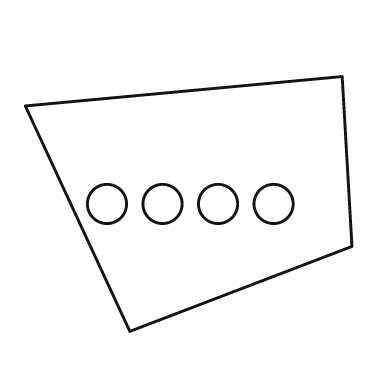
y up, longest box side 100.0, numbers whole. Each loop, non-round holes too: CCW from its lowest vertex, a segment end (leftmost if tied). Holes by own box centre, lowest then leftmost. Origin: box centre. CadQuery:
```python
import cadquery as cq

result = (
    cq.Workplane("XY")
    .moveTo(-18.0, -39.0)
    .lineTo(50.0, -13.0)
    .lineTo(47.0, 39.0)
    .lineTo(-50.0, 30.0)
    .close()
    .moveTo(-25.0, 0.0)
    .circle(6.0)
    .moveTo(-8.0, 0.0)
    .circle(6.0)
    .moveTo(9.0, 0.0)
    .circle(6.0)
    .moveTo(26.0, 0.0)
    .circle(6.0)
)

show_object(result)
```